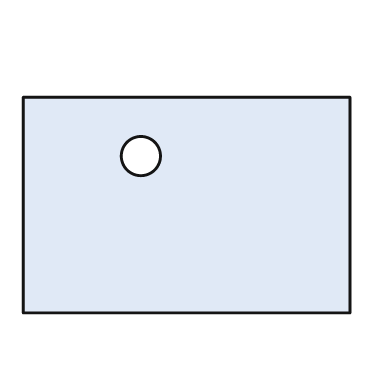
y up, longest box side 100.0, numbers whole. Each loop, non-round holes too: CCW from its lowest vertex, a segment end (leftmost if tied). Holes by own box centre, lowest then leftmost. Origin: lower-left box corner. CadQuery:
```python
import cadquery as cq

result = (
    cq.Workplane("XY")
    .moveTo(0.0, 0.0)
    .lineTo(100.0, 0.0)
    .lineTo(100.0, 66.0)
    .lineTo(0.0, 66.0)
    .close()
    .moveTo(36.0, 48.0)
    .circle(6.0)
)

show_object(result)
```